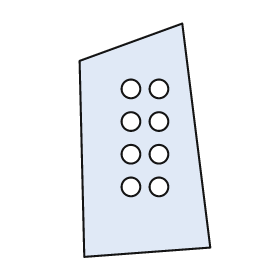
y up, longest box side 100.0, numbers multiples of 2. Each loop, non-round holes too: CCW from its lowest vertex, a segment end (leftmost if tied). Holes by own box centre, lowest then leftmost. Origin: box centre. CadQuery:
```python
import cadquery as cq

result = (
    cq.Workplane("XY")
    .moveTo(-26.0, -50.0)
    .lineTo(28.0, -46.0)
    .lineTo(16.0, 50.0)
    .lineTo(-28.0, 34.0)
    .close()
    .moveTo(-6.0, -20.0)
    .circle(4.0)
    .moveTo(6.0, -20.0)
    .circle(4.0)
    .moveTo(-6.0, -6.0)
    .circle(4.0)
    .moveTo(6.0, -6.0)
    .circle(4.0)
    .moveTo(-6.0, 8.0)
    .circle(4.0)
    .moveTo(6.0, 8.0)
    .circle(4.0)
    .moveTo(-6.0, 22.0)
    .circle(4.0)
    .moveTo(6.0, 22.0)
    .circle(4.0)
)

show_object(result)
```